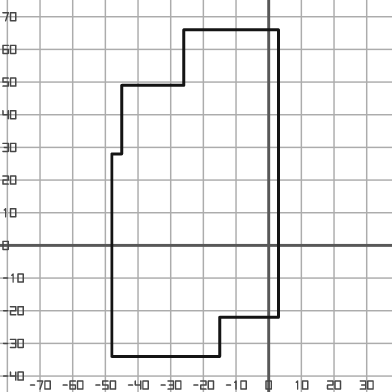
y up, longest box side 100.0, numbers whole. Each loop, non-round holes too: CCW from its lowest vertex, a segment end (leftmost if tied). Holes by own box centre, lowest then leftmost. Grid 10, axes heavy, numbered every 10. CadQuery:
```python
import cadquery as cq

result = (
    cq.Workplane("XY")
    .moveTo(-48.0, -34.0)
    .lineTo(-15.0, -34.0)
    .lineTo(-15.0, -22.0)
    .lineTo(3.0, -22.0)
    .lineTo(3.0, 66.0)
    .lineTo(-26.0, 66.0)
    .lineTo(-26.0, 49.0)
    .lineTo(-45.0, 49.0)
    .lineTo(-45.0, 28.0)
    .lineTo(-48.0, 28.0)
    .close()
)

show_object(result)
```